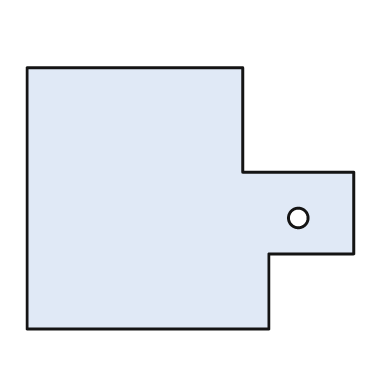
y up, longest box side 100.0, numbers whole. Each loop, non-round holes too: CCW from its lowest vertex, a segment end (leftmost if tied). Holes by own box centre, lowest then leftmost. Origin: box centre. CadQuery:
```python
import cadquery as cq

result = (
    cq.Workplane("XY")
    .moveTo(-50.0, -40.0)
    .lineTo(24.0, -40.0)
    .lineTo(24.0, -17.0)
    .lineTo(50.0, -17.0)
    .lineTo(50.0, 8.0)
    .lineTo(16.0, 8.0)
    .lineTo(16.0, 40.0)
    .lineTo(-50.0, 40.0)
    .close()
    .moveTo(33.0, -6.0)
    .circle(3.0)
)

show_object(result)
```